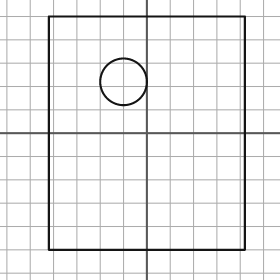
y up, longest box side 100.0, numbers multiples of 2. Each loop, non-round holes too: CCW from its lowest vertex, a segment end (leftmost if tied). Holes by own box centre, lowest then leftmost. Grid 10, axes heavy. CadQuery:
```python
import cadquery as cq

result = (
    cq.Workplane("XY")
    .moveTo(-42.0, -50.0)
    .lineTo(42.0, -50.0)
    .lineTo(42.0, 50.0)
    .lineTo(-42.0, 50.0)
    .close()
    .moveTo(-10.0, 22.0)
    .circle(10.0)
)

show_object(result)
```